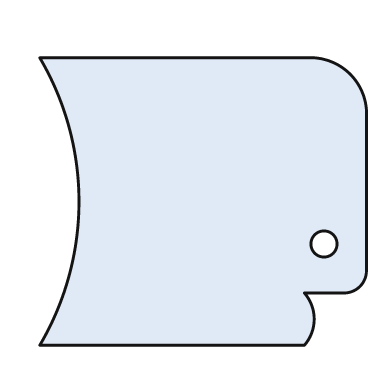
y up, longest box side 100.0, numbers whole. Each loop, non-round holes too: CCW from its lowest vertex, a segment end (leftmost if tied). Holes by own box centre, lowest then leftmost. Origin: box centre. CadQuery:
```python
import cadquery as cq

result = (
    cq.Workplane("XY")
    .moveTo(-50.0, -44.0)
    .lineTo(31.0, -44.0)
    .threePointArc((34.0, -36.0), (31.0, -28.0))
    .lineTo(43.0, -28.0)
    .threePointArc((48.0, -26.0), (50.0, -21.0))
    .lineTo(50.0, 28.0)
    .threePointArc((45.0, 39.0), (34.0, 44.0))
    .lineTo(-50.0, 44.0)
    .threePointArc((-38.0, 0.0), (-50.0, -44.0))
    .close()
    .moveTo(37.0, -13.0)
    .circle(4.0)
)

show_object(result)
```